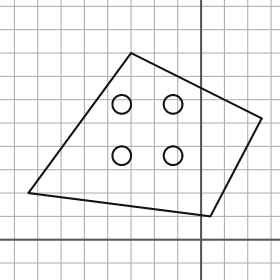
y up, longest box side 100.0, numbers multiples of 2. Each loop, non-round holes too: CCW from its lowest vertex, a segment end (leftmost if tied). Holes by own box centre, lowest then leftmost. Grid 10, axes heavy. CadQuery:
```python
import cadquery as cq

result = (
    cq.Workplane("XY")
    .moveTo(4.0, 10.0)
    .lineTo(26.0, 52.0)
    .lineTo(-30.0, 80.0)
    .lineTo(-74.0, 20.0)
    .close()
    .moveTo(-34.0, 36.0)
    .circle(4.0)
    .moveTo(-12.0, 36.0)
    .circle(4.0)
    .moveTo(-34.0, 58.0)
    .circle(4.0)
    .moveTo(-12.0, 58.0)
    .circle(4.0)
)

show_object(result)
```